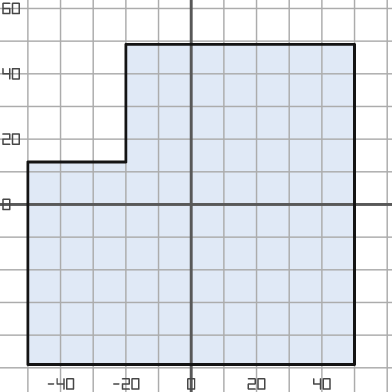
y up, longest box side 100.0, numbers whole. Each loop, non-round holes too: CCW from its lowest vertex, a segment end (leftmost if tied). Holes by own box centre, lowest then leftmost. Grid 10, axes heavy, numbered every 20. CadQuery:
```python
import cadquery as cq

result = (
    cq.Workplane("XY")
    .moveTo(-50.0, -49.0)
    .lineTo(50.0, -49.0)
    .lineTo(50.0, 49.0)
    .lineTo(-20.0, 49.0)
    .lineTo(-20.0, 13.0)
    .lineTo(-50.0, 13.0)
    .close()
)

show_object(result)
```